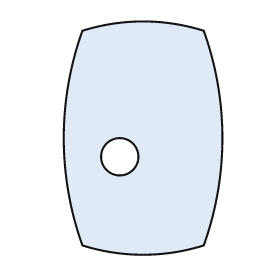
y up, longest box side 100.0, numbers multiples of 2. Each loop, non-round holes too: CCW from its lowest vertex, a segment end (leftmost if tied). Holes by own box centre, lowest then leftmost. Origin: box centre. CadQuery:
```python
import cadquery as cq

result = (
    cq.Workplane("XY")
    .moveTo(-26.0, -46.0)
    .threePointArc((0.0, -50.0), (26.0, -46.0))
    .threePointArc((34.0, 0.0), (26.0, 46.0))
    .threePointArc((0.0, 50.0), (-26.0, 46.0))
    .threePointArc((-34.0, 0.0), (-26.0, -46.0))
    .close()
    .moveTo(-10.0, -8.0)
    .circle(8.0)
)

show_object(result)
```